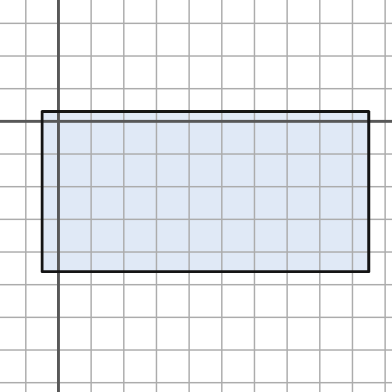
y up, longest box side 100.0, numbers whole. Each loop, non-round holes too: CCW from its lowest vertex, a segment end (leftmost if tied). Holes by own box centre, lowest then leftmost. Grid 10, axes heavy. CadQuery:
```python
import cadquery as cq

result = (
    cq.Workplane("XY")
    .moveTo(-5.0, -46.0)
    .lineTo(95.0, -46.0)
    .lineTo(95.0, 3.0)
    .lineTo(-5.0, 3.0)
    .close()
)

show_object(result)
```